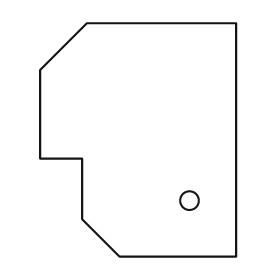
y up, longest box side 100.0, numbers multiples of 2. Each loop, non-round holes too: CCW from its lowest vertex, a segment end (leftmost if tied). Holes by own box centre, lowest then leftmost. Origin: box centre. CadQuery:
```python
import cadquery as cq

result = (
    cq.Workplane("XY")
    .moveTo(-8.0, -50.0)
    .lineTo(42.0, -50.0)
    .lineTo(42.0, 50.0)
    .lineTo(-22.0, 50.0)
    .lineTo(-42.0, 30.0)
    .lineTo(-42.0, -8.0)
    .lineTo(-24.0, -8.0)
    .lineTo(-24.0, -34.0)
    .close()
    .moveTo(22.0, -26.0)
    .circle(4.0)
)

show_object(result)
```